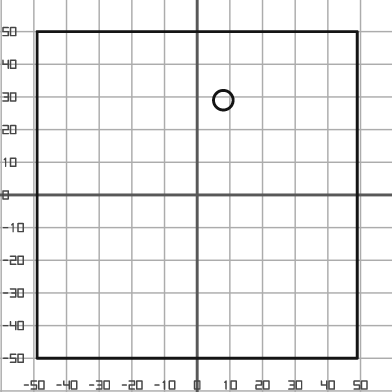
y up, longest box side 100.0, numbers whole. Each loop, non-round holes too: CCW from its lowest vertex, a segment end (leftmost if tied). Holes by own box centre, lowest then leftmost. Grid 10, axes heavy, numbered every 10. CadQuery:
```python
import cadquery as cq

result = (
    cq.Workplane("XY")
    .moveTo(-49.0, -50.0)
    .lineTo(49.0, -50.0)
    .lineTo(49.0, 50.0)
    .lineTo(-49.0, 50.0)
    .close()
    .moveTo(8.0, 29.0)
    .circle(3.0)
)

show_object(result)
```